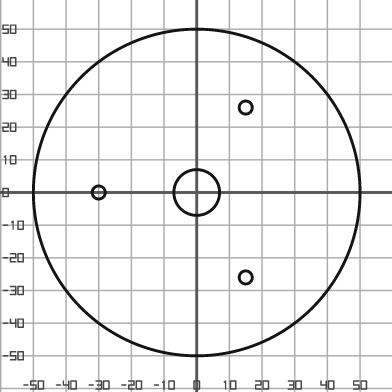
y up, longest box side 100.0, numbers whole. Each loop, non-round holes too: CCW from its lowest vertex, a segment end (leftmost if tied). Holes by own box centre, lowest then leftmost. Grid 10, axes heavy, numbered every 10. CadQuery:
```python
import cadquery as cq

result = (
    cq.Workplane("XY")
    .moveTo(0.0, 0.0)
    .circle(50.0)
    .moveTo(15.0, -26.0)
    .circle(2.0)
    .moveTo(-30.0, 0.0)
    .circle(2.0)
    .moveTo(0.0, 0.0)
    .circle(7.0)
    .moveTo(15.0, 26.0)
    .circle(2.0)
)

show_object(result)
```